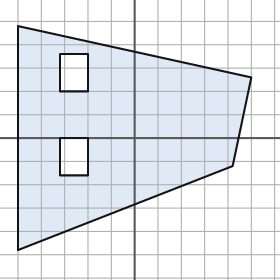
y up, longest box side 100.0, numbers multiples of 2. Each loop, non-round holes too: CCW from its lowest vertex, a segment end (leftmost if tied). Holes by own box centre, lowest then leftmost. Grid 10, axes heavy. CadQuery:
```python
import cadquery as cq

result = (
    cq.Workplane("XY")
    .moveTo(-50.0, -48.0)
    .lineTo(42.0, -12.0)
    .lineTo(50.0, 26.0)
    .lineTo(-50.0, 48.0)
    .close()
    .moveTo(-32.0, -16.0)
    .lineTo(-20.0, -16.0)
    .lineTo(-20.0, 0.0)
    .lineTo(-32.0, 0.0)
    .close()
    .moveTo(-32.0, 20.0)
    .lineTo(-20.0, 20.0)
    .lineTo(-20.0, 36.0)
    .lineTo(-32.0, 36.0)
    .close()
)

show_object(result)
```